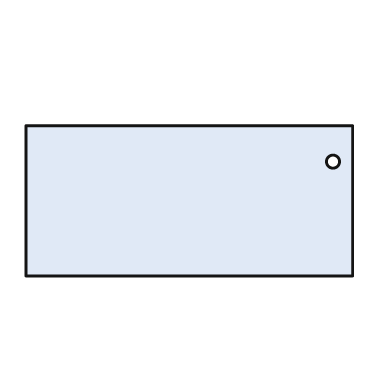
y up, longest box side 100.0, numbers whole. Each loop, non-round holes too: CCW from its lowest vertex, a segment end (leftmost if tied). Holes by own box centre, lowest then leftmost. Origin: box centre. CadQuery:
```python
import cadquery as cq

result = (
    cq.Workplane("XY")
    .moveTo(-50.0, -23.0)
    .lineTo(50.0, -23.0)
    .lineTo(50.0, 23.0)
    .lineTo(-50.0, 23.0)
    .close()
    .moveTo(44.0, 12.0)
    .circle(2.0)
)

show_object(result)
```